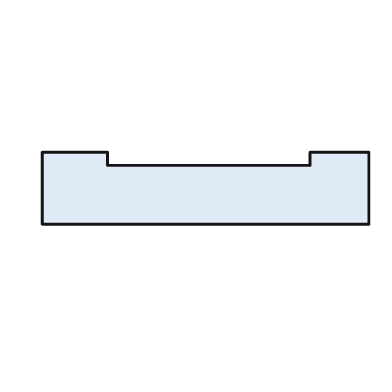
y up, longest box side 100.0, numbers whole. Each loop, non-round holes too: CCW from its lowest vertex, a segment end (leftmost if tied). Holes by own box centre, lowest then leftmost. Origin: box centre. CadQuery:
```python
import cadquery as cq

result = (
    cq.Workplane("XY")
    .moveTo(-50.0, -11.0)
    .lineTo(50.0, -11.0)
    .lineTo(50.0, 11.0)
    .lineTo(32.0, 11.0)
    .lineTo(32.0, 7.0)
    .lineTo(-30.0, 7.0)
    .lineTo(-30.0, 11.0)
    .lineTo(-50.0, 11.0)
    .close()
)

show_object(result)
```